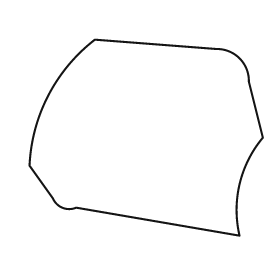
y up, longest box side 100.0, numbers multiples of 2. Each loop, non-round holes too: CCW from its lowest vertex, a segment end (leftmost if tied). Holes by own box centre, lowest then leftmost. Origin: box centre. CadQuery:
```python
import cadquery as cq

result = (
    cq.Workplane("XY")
    .moveTo(40.0, -42.0)
    .threePointArc((40.0, -20.0), (50.0, 0.0))
    .lineTo(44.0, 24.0)
    .threePointArc((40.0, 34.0), (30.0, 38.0))
    .lineTo(-22.0, 42.0)
    .threePointArc((-42.0, 18.0), (-50.0, -12.0))
    .lineTo(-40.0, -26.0)
    .threePointArc((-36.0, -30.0), (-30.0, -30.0))
    .close()
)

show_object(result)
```